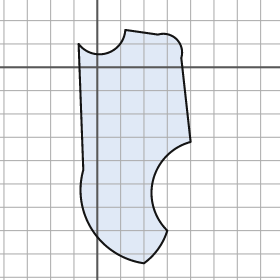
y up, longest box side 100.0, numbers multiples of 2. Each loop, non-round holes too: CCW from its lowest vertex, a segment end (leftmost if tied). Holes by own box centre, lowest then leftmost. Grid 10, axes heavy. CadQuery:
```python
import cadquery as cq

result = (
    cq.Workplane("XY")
    .moveTo(20.0, -84.0)
    .threePointArc((26.0, -78.0), (30.0, -70.0))
    .threePointArc((24.0, -48.0), (40.0, -32.0))
    .lineTo(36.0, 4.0)
    .threePointArc((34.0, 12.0), (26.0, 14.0))
    .lineTo(12.0, 16.0)
    .threePointArc((4.0, 6.0), (-8.0, 10.0))
    .lineTo(-6.0, -44.0)
    .threePointArc((-2.0, -70.0), (20.0, -84.0))
    .close()
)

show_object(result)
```